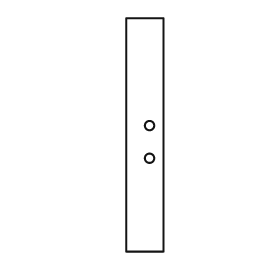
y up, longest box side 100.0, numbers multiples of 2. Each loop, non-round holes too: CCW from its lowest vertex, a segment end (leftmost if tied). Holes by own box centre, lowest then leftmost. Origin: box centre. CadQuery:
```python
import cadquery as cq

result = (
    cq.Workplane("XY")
    .moveTo(-8.0, -50.0)
    .lineTo(8.0, -50.0)
    .lineTo(8.0, 50.0)
    .lineTo(-8.0, 50.0)
    .close()
    .moveTo(2.0, -10.0)
    .circle(2.0)
    .moveTo(2.0, 4.0)
    .circle(2.0)
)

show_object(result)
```